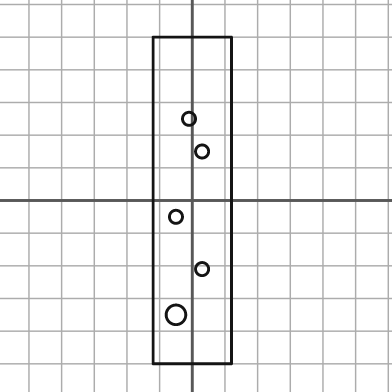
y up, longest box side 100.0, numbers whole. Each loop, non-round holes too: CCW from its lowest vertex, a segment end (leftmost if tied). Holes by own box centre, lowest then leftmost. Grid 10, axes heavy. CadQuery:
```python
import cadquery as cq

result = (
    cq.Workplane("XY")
    .moveTo(-12.0, -50.0)
    .lineTo(12.0, -50.0)
    .lineTo(12.0, 50.0)
    .lineTo(-12.0, 50.0)
    .close()
    .moveTo(-5.0, -35.0)
    .circle(3.0)
    .moveTo(3.0, -21.0)
    .circle(2.0)
    .moveTo(-5.0, -5.0)
    .circle(2.0)
    .moveTo(3.0, 15.0)
    .circle(2.0)
    .moveTo(-1.0, 25.0)
    .circle(2.0)
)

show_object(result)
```